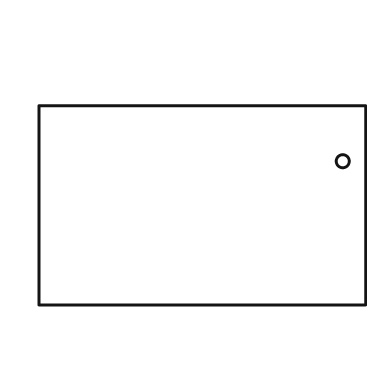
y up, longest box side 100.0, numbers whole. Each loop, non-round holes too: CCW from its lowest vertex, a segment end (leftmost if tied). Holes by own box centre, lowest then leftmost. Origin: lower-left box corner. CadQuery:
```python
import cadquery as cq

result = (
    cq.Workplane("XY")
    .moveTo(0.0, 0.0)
    .lineTo(100.0, 0.0)
    .lineTo(100.0, 61.0)
    .lineTo(0.0, 61.0)
    .close()
    .moveTo(93.0, 44.0)
    .circle(2.0)
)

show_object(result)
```